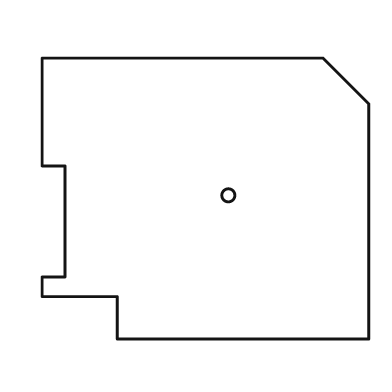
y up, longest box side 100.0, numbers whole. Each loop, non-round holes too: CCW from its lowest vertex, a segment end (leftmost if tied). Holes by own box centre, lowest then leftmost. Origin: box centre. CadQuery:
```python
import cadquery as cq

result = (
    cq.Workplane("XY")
    .moveTo(-27.0, -43.0)
    .lineTo(50.0, -43.0)
    .lineTo(50.0, 29.0)
    .lineTo(36.0, 43.0)
    .lineTo(-50.0, 43.0)
    .lineTo(-50.0, 10.0)
    .lineTo(-43.0, 10.0)
    .lineTo(-43.0, -24.0)
    .lineTo(-50.0, -24.0)
    .lineTo(-50.0, -30.0)
    .lineTo(-27.0, -30.0)
    .close()
    .moveTo(7.0, 1.0)
    .circle(2.0)
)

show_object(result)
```